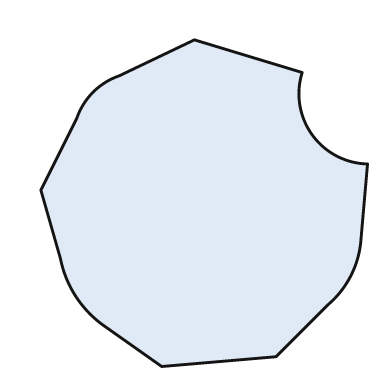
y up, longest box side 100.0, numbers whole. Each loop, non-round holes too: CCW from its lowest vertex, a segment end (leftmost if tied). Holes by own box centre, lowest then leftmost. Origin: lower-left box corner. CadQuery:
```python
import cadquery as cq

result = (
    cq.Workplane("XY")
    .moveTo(37.0, 0.0)
    .lineTo(72.0, 3.0)
    .lineTo(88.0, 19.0)
    .threePointArc((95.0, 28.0), (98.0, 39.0))
    .lineTo(100.0, 62.0)
    .threePointArc((83.0, 71.0), (80.0, 90.0))
    .lineTo(47.0, 100.0)
    .lineTo(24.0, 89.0)
    .threePointArc((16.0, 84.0), (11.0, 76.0))
    .lineTo(0.0, 54.0)
    .lineTo(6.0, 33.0)
    .threePointArc((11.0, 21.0), (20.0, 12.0))
    .close()
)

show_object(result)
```